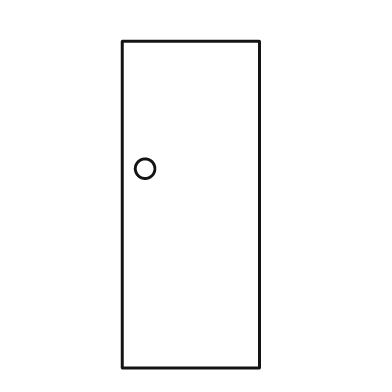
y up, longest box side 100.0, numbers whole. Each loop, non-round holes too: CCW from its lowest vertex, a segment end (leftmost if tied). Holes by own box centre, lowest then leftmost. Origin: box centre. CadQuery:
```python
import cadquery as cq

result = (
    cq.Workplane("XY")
    .moveTo(-21.0, -50.0)
    .lineTo(21.0, -50.0)
    .lineTo(21.0, 50.0)
    .lineTo(-21.0, 50.0)
    .close()
    .moveTo(-14.0, 11.0)
    .circle(3.0)
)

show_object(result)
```